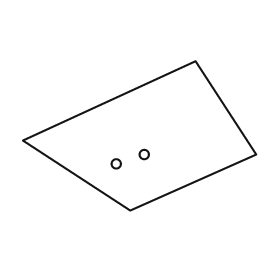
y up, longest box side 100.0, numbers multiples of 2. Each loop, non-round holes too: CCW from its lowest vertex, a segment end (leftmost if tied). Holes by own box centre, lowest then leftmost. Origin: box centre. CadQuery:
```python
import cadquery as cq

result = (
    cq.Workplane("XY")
    .moveTo(-4.0, -32.0)
    .lineTo(50.0, -8.0)
    .lineTo(24.0, 32.0)
    .lineTo(-50.0, -2.0)
    .close()
    .moveTo(-10.0, -12.0)
    .circle(2.0)
    .moveTo(2.0, -8.0)
    .circle(2.0)
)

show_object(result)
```